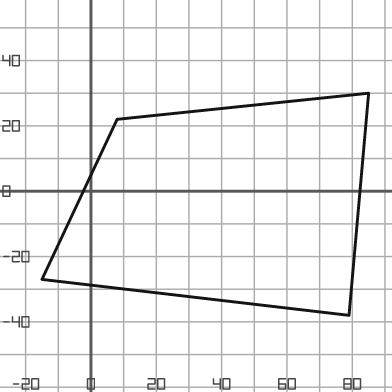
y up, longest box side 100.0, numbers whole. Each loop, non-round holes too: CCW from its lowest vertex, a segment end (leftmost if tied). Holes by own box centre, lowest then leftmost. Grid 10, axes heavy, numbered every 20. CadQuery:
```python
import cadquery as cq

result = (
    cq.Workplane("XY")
    .moveTo(79.0, -38.0)
    .lineTo(85.0, 30.0)
    .lineTo(8.0, 22.0)
    .lineTo(-15.0, -27.0)
    .close()
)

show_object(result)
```